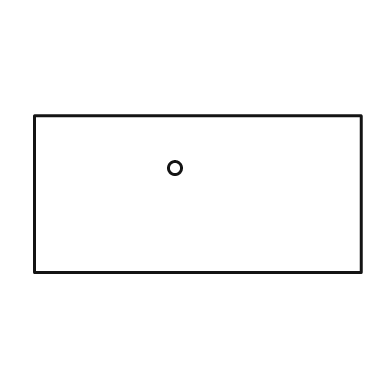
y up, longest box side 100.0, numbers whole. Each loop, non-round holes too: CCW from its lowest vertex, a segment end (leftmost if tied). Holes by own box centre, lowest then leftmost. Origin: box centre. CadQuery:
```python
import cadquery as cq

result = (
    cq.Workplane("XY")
    .moveTo(-50.0, -24.0)
    .lineTo(50.0, -24.0)
    .lineTo(50.0, 24.0)
    .lineTo(-50.0, 24.0)
    .close()
    .moveTo(-7.0, 8.0)
    .circle(2.0)
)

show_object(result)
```